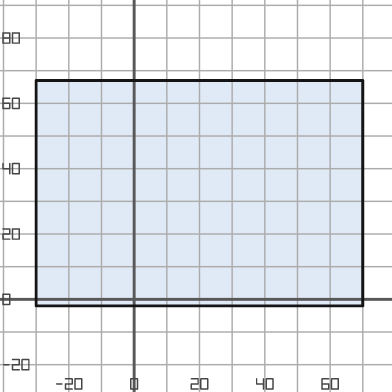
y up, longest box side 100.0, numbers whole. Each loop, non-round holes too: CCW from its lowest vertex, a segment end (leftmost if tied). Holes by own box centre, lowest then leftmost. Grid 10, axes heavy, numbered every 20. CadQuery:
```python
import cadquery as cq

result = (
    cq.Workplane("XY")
    .moveTo(-30.0, -2.0)
    .lineTo(70.0, -2.0)
    .lineTo(70.0, 67.0)
    .lineTo(-30.0, 67.0)
    .close()
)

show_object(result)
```